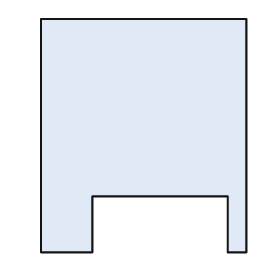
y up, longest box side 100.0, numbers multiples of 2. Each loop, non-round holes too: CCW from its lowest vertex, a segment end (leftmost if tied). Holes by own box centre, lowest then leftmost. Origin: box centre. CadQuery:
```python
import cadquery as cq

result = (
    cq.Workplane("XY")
    .moveTo(-44.0, -50.0)
    .lineTo(-22.0, -50.0)
    .lineTo(-22.0, -26.0)
    .lineTo(36.0, -26.0)
    .lineTo(36.0, -50.0)
    .lineTo(44.0, -50.0)
    .lineTo(44.0, 50.0)
    .lineTo(-44.0, 50.0)
    .close()
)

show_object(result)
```